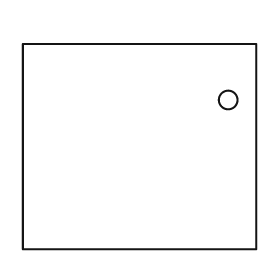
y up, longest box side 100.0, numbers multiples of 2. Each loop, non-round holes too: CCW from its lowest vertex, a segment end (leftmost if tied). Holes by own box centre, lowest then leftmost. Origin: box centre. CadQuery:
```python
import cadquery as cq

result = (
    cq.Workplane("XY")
    .moveTo(-50.0, -44.0)
    .lineTo(50.0, -44.0)
    .lineTo(50.0, 44.0)
    .lineTo(-50.0, 44.0)
    .close()
    .moveTo(38.0, 20.0)
    .circle(4.0)
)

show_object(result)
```